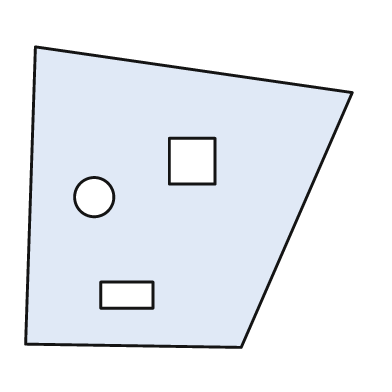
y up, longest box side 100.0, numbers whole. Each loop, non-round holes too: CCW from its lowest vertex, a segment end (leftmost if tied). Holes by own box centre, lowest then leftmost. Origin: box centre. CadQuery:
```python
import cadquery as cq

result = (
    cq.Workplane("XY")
    .moveTo(16.0, -46.0)
    .lineTo(50.0, 32.0)
    .lineTo(-47.0, 46.0)
    .lineTo(-50.0, -45.0)
    .close()
    .moveTo(-27.0, -34.0)
    .lineTo(-11.0, -34.0)
    .lineTo(-11.0, -26.0)
    .lineTo(-27.0, -26.0)
    .close()
    .moveTo(-29.0, 0.0)
    .circle(6.0)
    .moveTo(-6.0, 4.0)
    .lineTo(8.0, 4.0)
    .lineTo(8.0, 18.0)
    .lineTo(-6.0, 18.0)
    .close()
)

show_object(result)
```